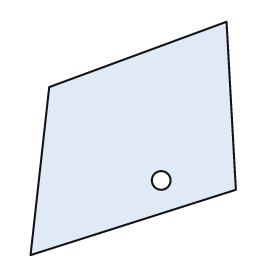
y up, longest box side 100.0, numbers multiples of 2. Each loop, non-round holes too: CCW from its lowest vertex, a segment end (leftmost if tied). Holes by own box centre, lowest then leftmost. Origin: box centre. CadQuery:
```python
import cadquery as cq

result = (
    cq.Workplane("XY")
    .moveTo(-44.0, -50.0)
    .lineTo(44.0, -22.0)
    .lineTo(40.0, 50.0)
    .lineTo(-36.0, 22.0)
    .close()
    .moveTo(12.0, -18.0)
    .circle(4.0)
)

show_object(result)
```